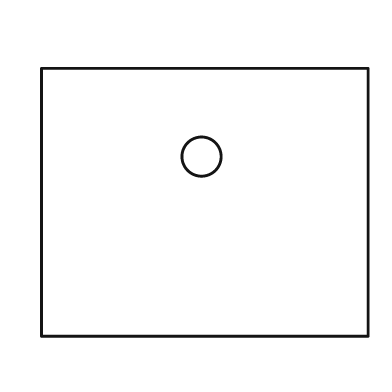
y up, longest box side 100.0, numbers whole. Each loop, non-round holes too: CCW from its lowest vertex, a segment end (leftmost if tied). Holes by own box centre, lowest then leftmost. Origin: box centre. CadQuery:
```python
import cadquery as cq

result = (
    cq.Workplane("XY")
    .moveTo(-50.0, -41.0)
    .lineTo(50.0, -41.0)
    .lineTo(50.0, 41.0)
    .lineTo(-50.0, 41.0)
    .close()
    .moveTo(-1.0, 14.0)
    .circle(6.0)
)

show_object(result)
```